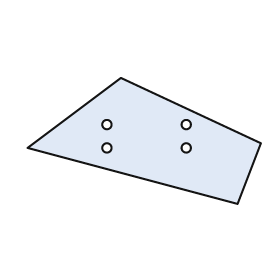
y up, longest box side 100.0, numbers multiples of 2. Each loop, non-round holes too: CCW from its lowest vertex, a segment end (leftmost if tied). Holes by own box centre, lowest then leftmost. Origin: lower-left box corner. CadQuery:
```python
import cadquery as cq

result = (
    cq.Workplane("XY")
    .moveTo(90.0, 0.0)
    .lineTo(100.0, 26.0)
    .lineTo(40.0, 54.0)
    .lineTo(0.0, 24.0)
    .close()
    .moveTo(34.0, 24.0)
    .circle(2.0)
    .moveTo(68.0, 24.0)
    .circle(2.0)
    .moveTo(34.0, 34.0)
    .circle(2.0)
    .moveTo(68.0, 34.0)
    .circle(2.0)
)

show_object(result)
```